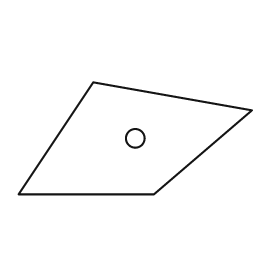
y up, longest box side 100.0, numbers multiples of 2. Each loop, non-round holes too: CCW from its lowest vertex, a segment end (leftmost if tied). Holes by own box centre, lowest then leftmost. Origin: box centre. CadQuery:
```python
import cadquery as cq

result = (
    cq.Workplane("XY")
    .moveTo(-50.0, -24.0)
    .lineTo(8.0, -24.0)
    .lineTo(50.0, 12.0)
    .lineTo(-18.0, 24.0)
    .close()
    .moveTo(0.0, 0.0)
    .circle(4.0)
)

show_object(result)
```